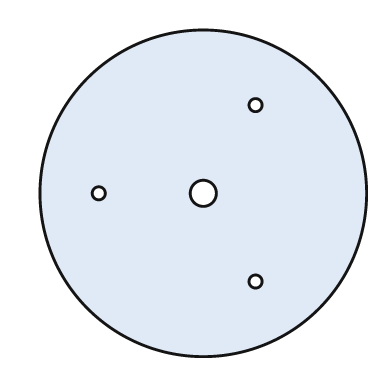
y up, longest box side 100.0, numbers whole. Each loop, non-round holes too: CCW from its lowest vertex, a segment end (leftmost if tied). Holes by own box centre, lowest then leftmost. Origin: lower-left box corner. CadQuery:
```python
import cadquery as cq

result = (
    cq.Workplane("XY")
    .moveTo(50.0, 50.0)
    .circle(50.0)
    .moveTo(66.0, 23.0)
    .circle(2.0)
    .moveTo(18.0, 50.0)
    .circle(2.0)
    .moveTo(50.0, 50.0)
    .circle(4.0)
    .moveTo(66.0, 77.0)
    .circle(2.0)
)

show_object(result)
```